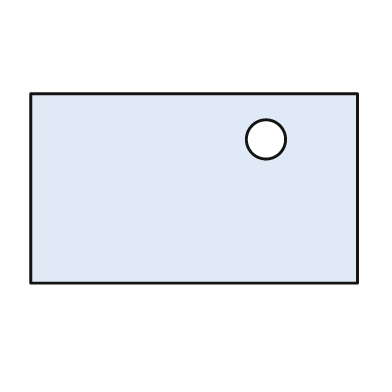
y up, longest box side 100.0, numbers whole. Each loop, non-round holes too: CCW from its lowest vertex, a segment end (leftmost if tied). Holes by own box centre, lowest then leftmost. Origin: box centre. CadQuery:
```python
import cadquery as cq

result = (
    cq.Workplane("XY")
    .moveTo(-50.0, -29.0)
    .lineTo(50.0, -29.0)
    .lineTo(50.0, 29.0)
    .lineTo(-50.0, 29.0)
    .close()
    .moveTo(22.0, 15.0)
    .circle(6.0)
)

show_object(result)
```